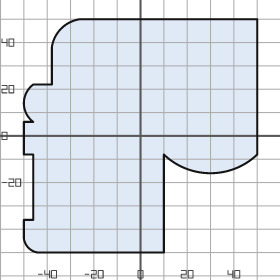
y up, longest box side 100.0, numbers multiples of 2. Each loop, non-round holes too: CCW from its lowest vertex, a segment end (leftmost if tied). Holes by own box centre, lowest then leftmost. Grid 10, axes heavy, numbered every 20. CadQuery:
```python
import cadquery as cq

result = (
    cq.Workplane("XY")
    .moveTo(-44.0, -50.0)
    .lineTo(10.0, -50.0)
    .lineTo(10.0, -8.0)
    .threePointArc((30.0, -16.0), (50.0, -8.0))
    .lineTo(50.0, 50.0)
    .lineTo(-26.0, 50.0)
    .threePointArc((-34.0, 46.0), (-38.0, 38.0))
    .lineTo(-38.0, 22.0)
    .lineTo(-46.0, 22.0)
    .threePointArc((-50.0, 14.0), (-46.0, 6.0))
    .lineTo(-50.0, 6.0)
    .lineTo(-50.0, -8.0)
    .lineTo(-46.0, -8.0)
    .lineTo(-46.0, -36.0)
    .lineTo(-50.0, -36.0)
    .lineTo(-50.0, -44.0)
    .threePointArc((-48.0, -48.0), (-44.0, -50.0))
    .close()
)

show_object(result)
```